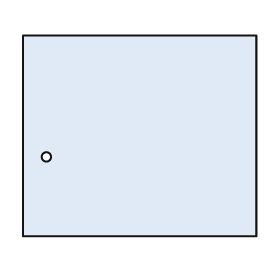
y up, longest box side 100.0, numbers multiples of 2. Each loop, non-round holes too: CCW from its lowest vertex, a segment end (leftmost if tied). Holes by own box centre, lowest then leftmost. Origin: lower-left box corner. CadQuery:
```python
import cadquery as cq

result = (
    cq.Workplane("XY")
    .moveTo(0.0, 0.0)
    .lineTo(100.0, 0.0)
    .lineTo(100.0, 86.0)
    .lineTo(0.0, 86.0)
    .close()
    .moveTo(10.0, 34.0)
    .circle(2.0)
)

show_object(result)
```